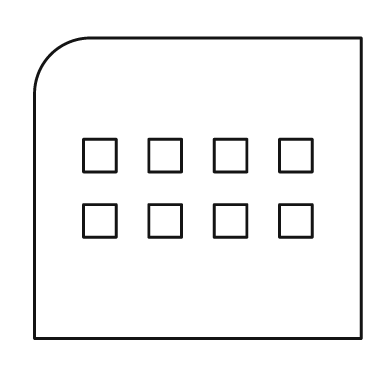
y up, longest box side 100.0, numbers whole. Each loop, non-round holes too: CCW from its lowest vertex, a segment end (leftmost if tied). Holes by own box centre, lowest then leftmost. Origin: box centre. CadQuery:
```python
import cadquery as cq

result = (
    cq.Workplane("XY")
    .moveTo(-50.0, -46.0)
    .lineTo(50.0, -46.0)
    .lineTo(50.0, 46.0)
    .lineTo(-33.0, 46.0)
    .threePointArc((-45.0, 41.0), (-50.0, 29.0))
    .close()
    .moveTo(-35.0, -15.0)
    .lineTo(-25.0, -15.0)
    .lineTo(-25.0, -5.0)
    .lineTo(-35.0, -5.0)
    .close()
    .moveTo(-15.0, -15.0)
    .lineTo(-5.0, -15.0)
    .lineTo(-5.0, -5.0)
    .lineTo(-15.0, -5.0)
    .close()
    .moveTo(5.0, -15.0)
    .lineTo(15.0, -15.0)
    .lineTo(15.0, -5.0)
    .lineTo(5.0, -5.0)
    .close()
    .moveTo(25.0, -15.0)
    .lineTo(35.0, -15.0)
    .lineTo(35.0, -5.0)
    .lineTo(25.0, -5.0)
    .close()
    .moveTo(-35.0, 5.0)
    .lineTo(-25.0, 5.0)
    .lineTo(-25.0, 15.0)
    .lineTo(-35.0, 15.0)
    .close()
    .moveTo(-15.0, 5.0)
    .lineTo(-5.0, 5.0)
    .lineTo(-5.0, 15.0)
    .lineTo(-15.0, 15.0)
    .close()
    .moveTo(5.0, 5.0)
    .lineTo(15.0, 5.0)
    .lineTo(15.0, 15.0)
    .lineTo(5.0, 15.0)
    .close()
    .moveTo(25.0, 5.0)
    .lineTo(35.0, 5.0)
    .lineTo(35.0, 15.0)
    .lineTo(25.0, 15.0)
    .close()
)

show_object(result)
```